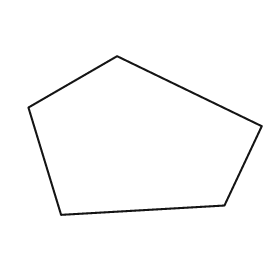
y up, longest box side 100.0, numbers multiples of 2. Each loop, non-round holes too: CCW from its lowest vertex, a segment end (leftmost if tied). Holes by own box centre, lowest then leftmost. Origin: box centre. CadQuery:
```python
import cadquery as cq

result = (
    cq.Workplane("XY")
    .moveTo(-36.0, -34.0)
    .lineTo(34.0, -30.0)
    .lineTo(50.0, 4.0)
    .lineTo(-12.0, 34.0)
    .lineTo(-50.0, 12.0)
    .close()
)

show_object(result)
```